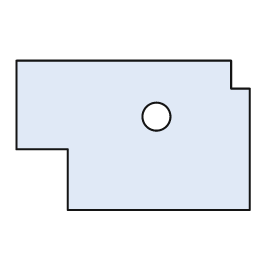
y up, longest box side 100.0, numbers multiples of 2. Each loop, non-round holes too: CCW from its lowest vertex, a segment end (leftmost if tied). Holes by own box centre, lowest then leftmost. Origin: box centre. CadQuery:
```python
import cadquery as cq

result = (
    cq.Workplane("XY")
    .moveTo(-28.0, -32.0)
    .lineTo(50.0, -32.0)
    .lineTo(50.0, 20.0)
    .lineTo(42.0, 20.0)
    .lineTo(42.0, 32.0)
    .lineTo(-50.0, 32.0)
    .lineTo(-50.0, -6.0)
    .lineTo(-28.0, -6.0)
    .close()
    .moveTo(10.0, 8.0)
    .circle(6.0)
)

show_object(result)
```